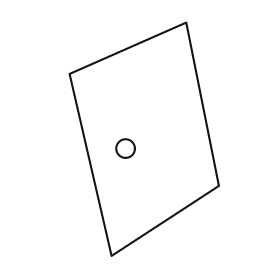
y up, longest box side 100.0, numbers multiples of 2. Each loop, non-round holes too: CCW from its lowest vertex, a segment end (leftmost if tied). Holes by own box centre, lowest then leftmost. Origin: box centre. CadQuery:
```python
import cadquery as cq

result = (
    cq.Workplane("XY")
    .moveTo(-14.0, -50.0)
    .lineTo(32.0, -20.0)
    .lineTo(18.0, 50.0)
    .lineTo(-32.0, 28.0)
    .close()
    .moveTo(-8.0, -4.0)
    .circle(4.0)
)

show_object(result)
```